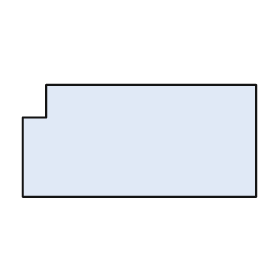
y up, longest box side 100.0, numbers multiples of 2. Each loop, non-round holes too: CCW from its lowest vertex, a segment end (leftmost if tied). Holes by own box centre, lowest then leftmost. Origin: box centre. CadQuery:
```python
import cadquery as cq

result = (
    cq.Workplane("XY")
    .moveTo(-50.0, -24.0)
    .lineTo(50.0, -24.0)
    .lineTo(50.0, 24.0)
    .lineTo(-40.0, 24.0)
    .lineTo(-40.0, 10.0)
    .lineTo(-50.0, 10.0)
    .close()
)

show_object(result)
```